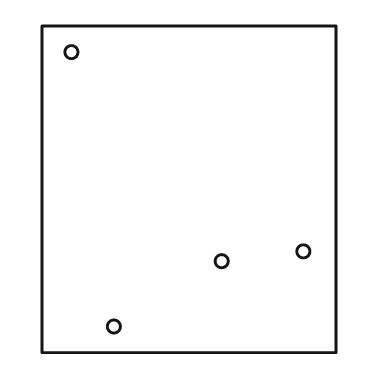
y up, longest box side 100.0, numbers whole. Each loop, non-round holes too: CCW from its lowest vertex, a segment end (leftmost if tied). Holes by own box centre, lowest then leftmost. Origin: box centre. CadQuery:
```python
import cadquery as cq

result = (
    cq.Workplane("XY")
    .moveTo(-45.0, -50.0)
    .lineTo(45.0, -50.0)
    .lineTo(45.0, 50.0)
    .lineTo(-45.0, 50.0)
    .close()
    .moveTo(-23.0, -42.0)
    .circle(2.0)
    .moveTo(10.0, -22.0)
    .circle(2.0)
    .moveTo(35.0, -19.0)
    .circle(2.0)
    .moveTo(-36.0, 42.0)
    .circle(2.0)
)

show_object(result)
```